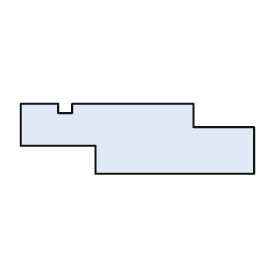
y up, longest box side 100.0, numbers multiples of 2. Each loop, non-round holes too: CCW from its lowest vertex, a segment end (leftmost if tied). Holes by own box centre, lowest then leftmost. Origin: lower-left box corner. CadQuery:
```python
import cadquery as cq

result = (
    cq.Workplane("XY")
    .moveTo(32.0, 0.0)
    .lineTo(100.0, 0.0)
    .lineTo(100.0, 20.0)
    .lineTo(74.0, 20.0)
    .lineTo(74.0, 30.0)
    .lineTo(22.0, 30.0)
    .lineTo(22.0, 26.0)
    .lineTo(16.0, 26.0)
    .lineTo(16.0, 30.0)
    .lineTo(0.0, 30.0)
    .lineTo(0.0, 12.0)
    .lineTo(32.0, 12.0)
    .close()
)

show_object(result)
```